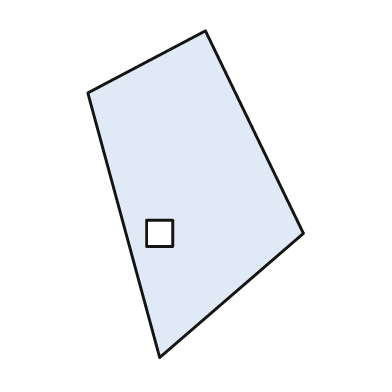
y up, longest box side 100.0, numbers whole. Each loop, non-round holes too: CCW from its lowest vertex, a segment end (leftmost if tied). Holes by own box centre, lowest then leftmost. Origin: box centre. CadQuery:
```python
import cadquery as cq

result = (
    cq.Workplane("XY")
    .moveTo(-11.0, -50.0)
    .lineTo(33.0, -12.0)
    .lineTo(3.0, 50.0)
    .lineTo(-33.0, 31.0)
    .close()
    .moveTo(-15.0, -16.0)
    .lineTo(-7.0, -16.0)
    .lineTo(-7.0, -8.0)
    .lineTo(-15.0, -8.0)
    .close()
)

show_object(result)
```